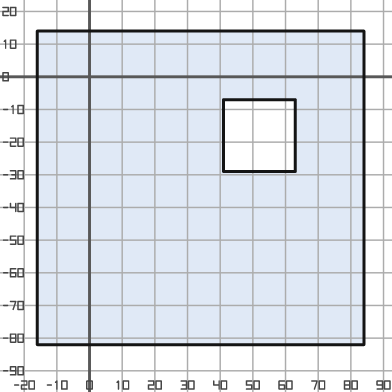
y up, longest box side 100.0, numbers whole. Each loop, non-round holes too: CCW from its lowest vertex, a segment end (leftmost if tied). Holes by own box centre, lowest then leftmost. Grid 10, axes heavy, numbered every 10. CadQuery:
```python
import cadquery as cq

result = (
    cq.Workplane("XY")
    .moveTo(-16.0, -82.0)
    .lineTo(84.0, -82.0)
    .lineTo(84.0, 14.0)
    .lineTo(-16.0, 14.0)
    .close()
    .moveTo(41.0, -29.0)
    .lineTo(63.0, -29.0)
    .lineTo(63.0, -7.0)
    .lineTo(41.0, -7.0)
    .close()
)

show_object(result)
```